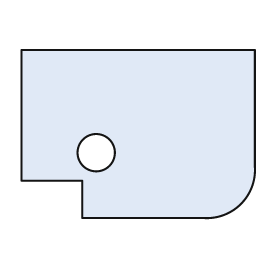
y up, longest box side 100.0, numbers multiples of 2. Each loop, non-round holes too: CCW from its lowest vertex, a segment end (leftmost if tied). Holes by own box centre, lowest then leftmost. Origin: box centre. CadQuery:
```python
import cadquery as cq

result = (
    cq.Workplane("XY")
    .moveTo(-24.0, -36.0)
    .lineTo(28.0, -36.0)
    .threePointArc((44.0, -30.0), (50.0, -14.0))
    .lineTo(50.0, 36.0)
    .lineTo(-50.0, 36.0)
    .lineTo(-50.0, -20.0)
    .lineTo(-24.0, -20.0)
    .close()
    .moveTo(-18.0, -8.0)
    .circle(8.0)
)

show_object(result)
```